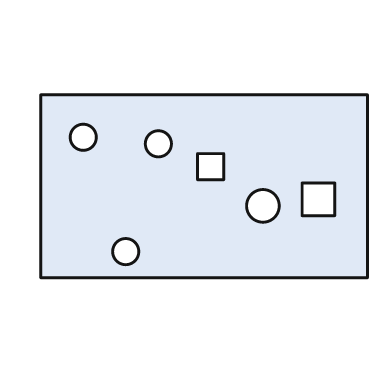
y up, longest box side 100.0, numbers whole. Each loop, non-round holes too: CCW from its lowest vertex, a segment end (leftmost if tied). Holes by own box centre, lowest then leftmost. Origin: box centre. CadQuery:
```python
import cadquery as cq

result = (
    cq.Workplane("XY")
    .moveTo(-50.0, -28.0)
    .lineTo(50.0, -28.0)
    .lineTo(50.0, 28.0)
    .lineTo(-50.0, 28.0)
    .close()
    .moveTo(-24.0, -20.0)
    .circle(4.0)
    .moveTo(18.0, -6.0)
    .circle(5.0)
    .moveTo(30.0, -9.0)
    .lineTo(40.0, -9.0)
    .lineTo(40.0, 1.0)
    .lineTo(30.0, 1.0)
    .close()
    .moveTo(-2.0, 2.0)
    .lineTo(6.0, 2.0)
    .lineTo(6.0, 10.0)
    .lineTo(-2.0, 10.0)
    .close()
    .moveTo(-14.0, 13.0)
    .circle(4.0)
    .moveTo(-37.0, 15.0)
    .circle(4.0)
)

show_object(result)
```